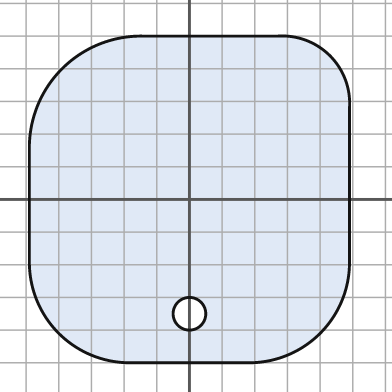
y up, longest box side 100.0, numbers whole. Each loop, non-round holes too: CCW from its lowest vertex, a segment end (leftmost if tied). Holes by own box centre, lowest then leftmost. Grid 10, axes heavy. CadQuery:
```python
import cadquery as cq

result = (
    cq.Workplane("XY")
    .moveTo(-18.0, -50.0)
    .lineTo(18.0, -50.0)
    .threePointArc((40.0, -41.0), (49.0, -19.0))
    .lineTo(49.0, 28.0)
    .threePointArc((43.0, 44.0), (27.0, 50.0))
    .lineTo(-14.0, 50.0)
    .threePointArc((-39.0, 40.0), (-49.0, 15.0))
    .lineTo(-49.0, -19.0)
    .threePointArc((-40.0, -41.0), (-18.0, -50.0))
    .close()
    .moveTo(0.0, -35.0)
    .circle(5.0)
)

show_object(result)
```